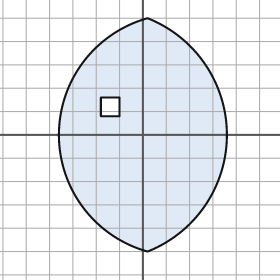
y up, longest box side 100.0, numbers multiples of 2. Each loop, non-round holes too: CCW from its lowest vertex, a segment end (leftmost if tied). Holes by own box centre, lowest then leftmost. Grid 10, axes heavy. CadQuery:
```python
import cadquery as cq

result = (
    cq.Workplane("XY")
    .moveTo(2.0, -50.0)
    .threePointArc((36.0, 0.0), (2.0, 50.0))
    .threePointArc((-36.0, 0.0), (2.0, -50.0))
    .close()
    .moveTo(-18.0, 8.0)
    .lineTo(-10.0, 8.0)
    .lineTo(-10.0, 16.0)
    .lineTo(-18.0, 16.0)
    .close()
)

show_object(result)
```